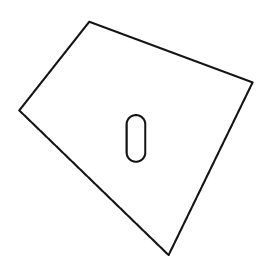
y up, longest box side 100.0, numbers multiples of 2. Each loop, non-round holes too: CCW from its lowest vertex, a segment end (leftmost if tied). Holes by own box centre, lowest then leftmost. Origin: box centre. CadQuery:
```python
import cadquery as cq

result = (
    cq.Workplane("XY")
    .moveTo(14.0, -50.0)
    .lineTo(50.0, 24.0)
    .lineTo(-20.0, 50.0)
    .lineTo(-50.0, 12.0)
    .close()
    .moveTo(-4.0, -6.0)
    .threePointArc((0.0, -10.0), (4.0, -6.0))
    .lineTo(4.0, 6.0)
    .threePointArc((0.0, 10.0), (-4.0, 6.0))
    .close()
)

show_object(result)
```